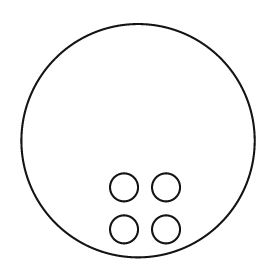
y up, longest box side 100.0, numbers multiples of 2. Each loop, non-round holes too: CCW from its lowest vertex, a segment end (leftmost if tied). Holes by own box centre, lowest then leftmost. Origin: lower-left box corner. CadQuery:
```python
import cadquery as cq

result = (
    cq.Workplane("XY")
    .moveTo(50.0, 50.0)
    .circle(50.0)
    .moveTo(44.0, 12.0)
    .circle(6.0)
    .moveTo(62.0, 12.0)
    .circle(6.0)
    .moveTo(44.0, 30.0)
    .circle(6.0)
    .moveTo(62.0, 30.0)
    .circle(6.0)
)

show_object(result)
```